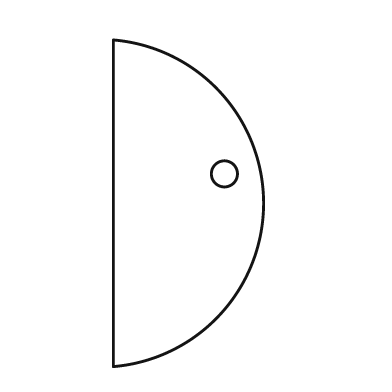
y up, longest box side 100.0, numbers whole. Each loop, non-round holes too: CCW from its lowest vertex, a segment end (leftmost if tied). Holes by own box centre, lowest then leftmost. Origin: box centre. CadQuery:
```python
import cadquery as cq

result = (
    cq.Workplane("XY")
    .moveTo(-23.0, -50.0)
    .threePointArc((23.0, 0.0), (-23.0, 50.0))
    .close()
    .moveTo(11.0, 9.0)
    .circle(4.0)
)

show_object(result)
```